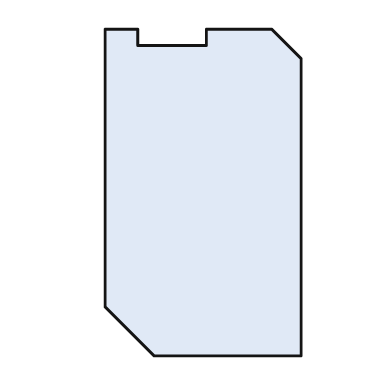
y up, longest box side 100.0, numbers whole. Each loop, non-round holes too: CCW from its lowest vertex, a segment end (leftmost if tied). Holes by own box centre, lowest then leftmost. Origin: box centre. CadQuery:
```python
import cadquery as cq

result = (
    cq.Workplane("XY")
    .moveTo(-15.0, -50.0)
    .lineTo(30.0, -50.0)
    .lineTo(30.0, 41.0)
    .lineTo(21.0, 50.0)
    .lineTo(1.0, 50.0)
    .lineTo(1.0, 45.0)
    .lineTo(-20.0, 45.0)
    .lineTo(-20.0, 50.0)
    .lineTo(-30.0, 50.0)
    .lineTo(-30.0, -35.0)
    .close()
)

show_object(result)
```